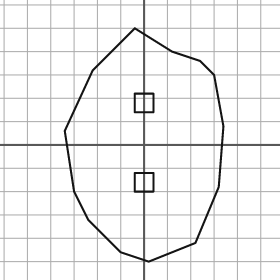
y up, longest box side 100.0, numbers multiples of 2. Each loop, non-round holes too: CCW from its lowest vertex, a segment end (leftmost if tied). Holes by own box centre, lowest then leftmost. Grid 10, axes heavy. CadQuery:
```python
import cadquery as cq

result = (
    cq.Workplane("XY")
    .moveTo(2.0, -50.0)
    .lineTo(22.0, -42.0)
    .lineTo(32.0, -18.0)
    .lineTo(34.0, 8.0)
    .lineTo(30.0, 30.0)
    .lineTo(24.0, 36.0)
    .lineTo(12.0, 40.0)
    .lineTo(-4.0, 50.0)
    .lineTo(-22.0, 32.0)
    .lineTo(-34.0, 6.0)
    .lineTo(-30.0, -20.0)
    .lineTo(-24.0, -32.0)
    .lineTo(-10.0, -46.0)
    .close()
    .moveTo(-4.0, -20.0)
    .lineTo(4.0, -20.0)
    .lineTo(4.0, -12.0)
    .lineTo(-4.0, -12.0)
    .close()
    .moveTo(-4.0, 14.0)
    .lineTo(4.0, 14.0)
    .lineTo(4.0, 22.0)
    .lineTo(-4.0, 22.0)
    .close()
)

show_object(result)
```